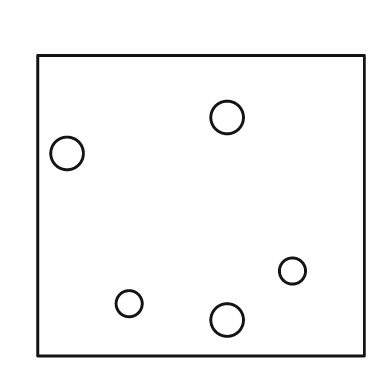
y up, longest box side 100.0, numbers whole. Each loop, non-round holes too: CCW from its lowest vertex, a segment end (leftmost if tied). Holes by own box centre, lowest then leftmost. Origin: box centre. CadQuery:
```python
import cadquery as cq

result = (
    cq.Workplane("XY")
    .moveTo(-50.0, -46.0)
    .lineTo(50.0, -46.0)
    .lineTo(50.0, 46.0)
    .lineTo(-50.0, 46.0)
    .close()
    .moveTo(8.0, -35.0)
    .circle(5.0)
    .moveTo(-22.0, -30.0)
    .circle(4.0)
    .moveTo(28.0, -20.0)
    .circle(4.0)
    .moveTo(-41.0, 16.0)
    .circle(5.0)
    .moveTo(8.0, 27.0)
    .circle(5.0)
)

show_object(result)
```